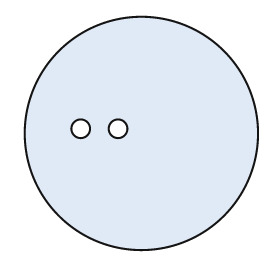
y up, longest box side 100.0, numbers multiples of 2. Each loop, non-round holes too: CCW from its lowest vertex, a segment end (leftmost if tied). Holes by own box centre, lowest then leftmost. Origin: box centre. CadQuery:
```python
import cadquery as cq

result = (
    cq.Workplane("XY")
    .moveTo(0.0, 0.0)
    .circle(50.0)
    .moveTo(-26.0, 2.0)
    .circle(4.0)
    .moveTo(-10.0, 2.0)
    .circle(4.0)
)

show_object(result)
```